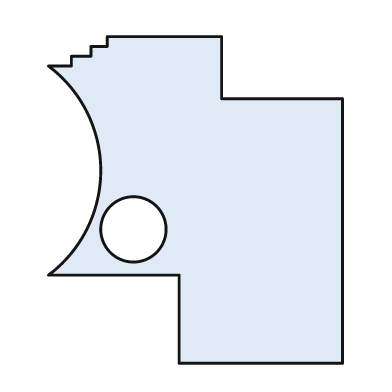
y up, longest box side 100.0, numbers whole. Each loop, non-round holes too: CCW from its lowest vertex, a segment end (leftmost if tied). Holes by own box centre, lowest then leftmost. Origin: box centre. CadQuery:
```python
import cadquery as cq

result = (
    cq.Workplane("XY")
    .moveTo(-5.0, -50.0)
    .lineTo(45.0, -50.0)
    .lineTo(45.0, 31.0)
    .lineTo(8.0, 31.0)
    .lineTo(8.0, 50.0)
    .lineTo(-27.0, 50.0)
    .lineTo(-27.0, 47.0)
    .lineTo(-32.0, 47.0)
    .lineTo(-32.0, 44.0)
    .lineTo(-38.0, 44.0)
    .lineTo(-38.0, 41.0)
    .lineTo(-45.0, 41.0)
    .threePointArc((-29.0, 9.0), (-45.0, -23.0))
    .lineTo(-5.0, -23.0)
    .close()
    .moveTo(-19.0, -9.0)
    .circle(10.0)
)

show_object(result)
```